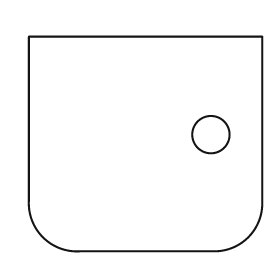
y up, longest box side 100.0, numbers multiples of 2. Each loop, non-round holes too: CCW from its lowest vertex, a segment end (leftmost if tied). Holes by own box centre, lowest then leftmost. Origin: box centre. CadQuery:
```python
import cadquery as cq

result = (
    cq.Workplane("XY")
    .moveTo(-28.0, -46.0)
    .lineTo(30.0, -46.0)
    .threePointArc((44.0, -40.0), (50.0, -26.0))
    .lineTo(50.0, 46.0)
    .lineTo(-50.0, 46.0)
    .lineTo(-50.0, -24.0)
    .threePointArc((-44.0, -40.0), (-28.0, -46.0))
    .close()
    .moveTo(28.0, 4.0)
    .circle(8.0)
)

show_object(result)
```